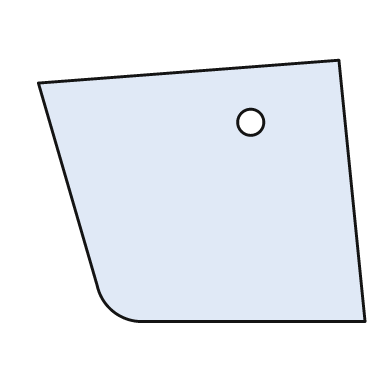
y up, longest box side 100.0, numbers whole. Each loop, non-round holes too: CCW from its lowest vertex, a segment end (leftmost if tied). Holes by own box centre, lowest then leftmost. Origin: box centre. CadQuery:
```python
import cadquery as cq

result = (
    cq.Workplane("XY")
    .moveTo(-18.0, -40.0)
    .lineTo(50.0, -40.0)
    .lineTo(42.0, 40.0)
    .lineTo(-50.0, 33.0)
    .lineTo(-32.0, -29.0)
    .threePointArc((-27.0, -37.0), (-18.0, -40.0))
    .close()
    .moveTo(15.0, 21.0)
    .circle(4.0)
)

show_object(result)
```